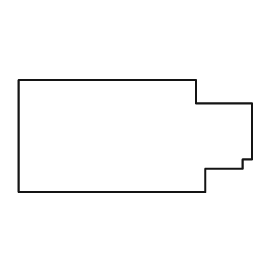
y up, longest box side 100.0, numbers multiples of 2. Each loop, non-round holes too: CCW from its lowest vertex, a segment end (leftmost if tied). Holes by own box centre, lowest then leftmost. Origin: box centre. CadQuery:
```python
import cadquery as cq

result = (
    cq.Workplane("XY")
    .moveTo(-50.0, -24.0)
    .lineTo(30.0, -24.0)
    .lineTo(30.0, -14.0)
    .lineTo(46.0, -14.0)
    .lineTo(46.0, -10.0)
    .lineTo(50.0, -10.0)
    .lineTo(50.0, 14.0)
    .lineTo(26.0, 14.0)
    .lineTo(26.0, 24.0)
    .lineTo(-50.0, 24.0)
    .close()
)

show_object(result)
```